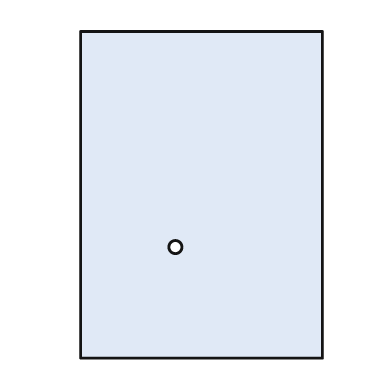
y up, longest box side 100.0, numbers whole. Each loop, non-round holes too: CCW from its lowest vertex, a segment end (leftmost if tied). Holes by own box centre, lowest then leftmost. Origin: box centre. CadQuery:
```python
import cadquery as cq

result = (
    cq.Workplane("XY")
    .moveTo(-37.0, -50.0)
    .lineTo(37.0, -50.0)
    .lineTo(37.0, 50.0)
    .lineTo(-37.0, 50.0)
    .close()
    .moveTo(-8.0, -16.0)
    .circle(2.0)
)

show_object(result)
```